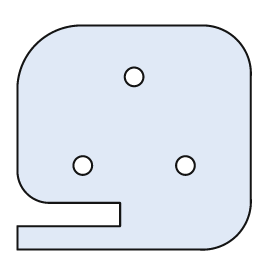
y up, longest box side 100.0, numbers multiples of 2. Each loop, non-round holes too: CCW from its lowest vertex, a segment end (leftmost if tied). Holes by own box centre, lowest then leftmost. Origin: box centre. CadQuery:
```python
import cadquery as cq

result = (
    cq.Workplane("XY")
    .moveTo(-50.0, -48.0)
    .lineTo(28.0, -48.0)
    .threePointArc((44.0, -42.0), (50.0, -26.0))
    .lineTo(50.0, 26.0)
    .threePointArc((44.0, 42.0), (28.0, 48.0))
    .lineTo(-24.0, 48.0)
    .threePointArc((-42.0, 40.0), (-50.0, 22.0))
    .lineTo(-50.0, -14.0)
    .threePointArc((-46.0, -24.0), (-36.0, -28.0))
    .lineTo(-6.0, -28.0)
    .lineTo(-6.0, -38.0)
    .lineTo(-50.0, -38.0)
    .close()
    .moveTo(-22.0, -12.0)
    .circle(4.0)
    .moveTo(22.0, -12.0)
    .circle(4.0)
    .moveTo(0.0, 26.0)
    .circle(4.0)
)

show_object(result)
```